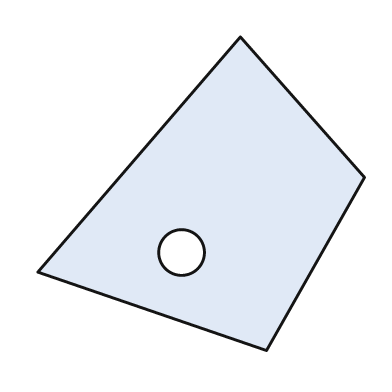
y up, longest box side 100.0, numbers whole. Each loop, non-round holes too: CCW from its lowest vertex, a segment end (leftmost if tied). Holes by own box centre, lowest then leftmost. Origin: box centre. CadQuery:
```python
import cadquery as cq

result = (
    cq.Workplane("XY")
    .moveTo(20.0, -48.0)
    .lineTo(50.0, 5.0)
    .lineTo(12.0, 48.0)
    .lineTo(-50.0, -24.0)
    .close()
    .moveTo(-6.0, -18.0)
    .circle(7.0)
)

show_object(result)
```